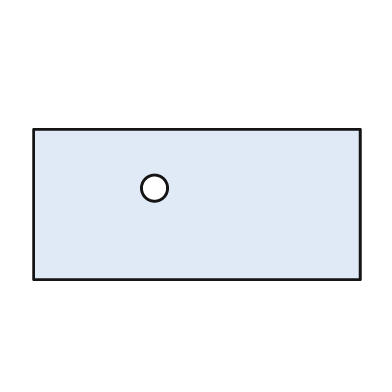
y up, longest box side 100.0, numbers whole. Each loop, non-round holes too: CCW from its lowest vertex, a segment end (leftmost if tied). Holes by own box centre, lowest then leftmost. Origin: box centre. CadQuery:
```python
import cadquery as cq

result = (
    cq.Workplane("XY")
    .moveTo(-50.0, -23.0)
    .lineTo(50.0, -23.0)
    .lineTo(50.0, 23.0)
    .lineTo(-50.0, 23.0)
    .close()
    .moveTo(-13.0, 5.0)
    .circle(4.0)
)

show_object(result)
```